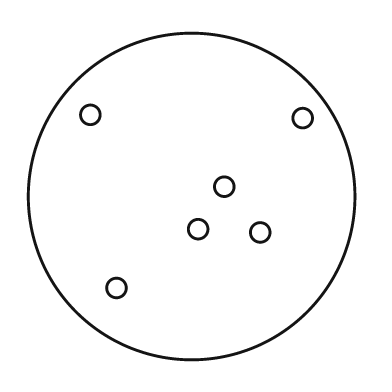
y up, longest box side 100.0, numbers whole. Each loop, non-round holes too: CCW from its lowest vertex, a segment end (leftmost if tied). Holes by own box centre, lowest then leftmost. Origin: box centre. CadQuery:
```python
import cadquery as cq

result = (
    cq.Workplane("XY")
    .moveTo(0.0, 0.0)
    .circle(50.0)
    .moveTo(-23.0, -28.0)
    .circle(3.0)
    .moveTo(21.0, -11.0)
    .circle(3.0)
    .moveTo(2.0, -10.0)
    .circle(3.0)
    .moveTo(10.0, 3.0)
    .circle(3.0)
    .moveTo(34.0, 24.0)
    .circle(3.0)
    .moveTo(-31.0, 25.0)
    .circle(3.0)
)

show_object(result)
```